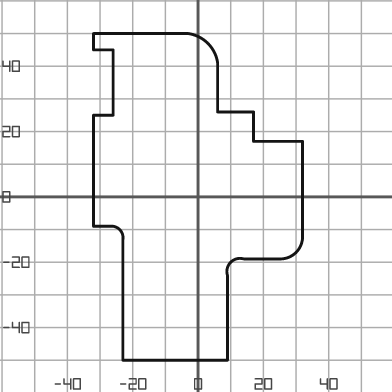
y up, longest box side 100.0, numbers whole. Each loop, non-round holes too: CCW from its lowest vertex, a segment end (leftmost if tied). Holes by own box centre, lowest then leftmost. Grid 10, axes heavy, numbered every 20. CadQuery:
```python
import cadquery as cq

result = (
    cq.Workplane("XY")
    .moveTo(-23.0, -50.0)
    .lineTo(9.0, -50.0)
    .lineTo(9.0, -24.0)
    .threePointArc((10.0, -20.0), (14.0, -19.0))
    .lineTo(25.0, -19.0)
    .threePointArc((30.0, -17.0), (32.0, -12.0))
    .lineTo(32.0, 17.0)
    .lineTo(17.0, 17.0)
    .lineTo(17.0, 26.0)
    .lineTo(6.0, 26.0)
    .lineTo(6.0, 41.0)
    .threePointArc((3.0, 47.0), (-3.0, 50.0))
    .lineTo(-32.0, 50.0)
    .lineTo(-32.0, 45.0)
    .lineTo(-26.0, 45.0)
    .lineTo(-26.0, 25.0)
    .lineTo(-32.0, 25.0)
    .lineTo(-32.0, -9.0)
    .lineTo(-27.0, -9.0)
    .threePointArc((-24.0, -10.0), (-23.0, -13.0))
    .close()
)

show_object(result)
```